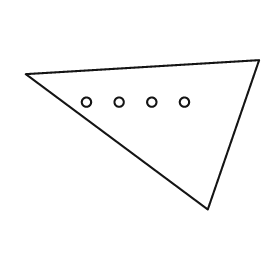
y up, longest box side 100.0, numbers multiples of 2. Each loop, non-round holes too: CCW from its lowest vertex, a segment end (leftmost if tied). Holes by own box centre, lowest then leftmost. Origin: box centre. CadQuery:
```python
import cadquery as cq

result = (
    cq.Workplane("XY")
    .moveTo(28.0, -32.0)
    .lineTo(50.0, 32.0)
    .lineTo(-50.0, 26.0)
    .close()
    .moveTo(-24.0, 14.0)
    .circle(2.0)
    .moveTo(-10.0, 14.0)
    .circle(2.0)
    .moveTo(4.0, 14.0)
    .circle(2.0)
    .moveTo(18.0, 14.0)
    .circle(2.0)
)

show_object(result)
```